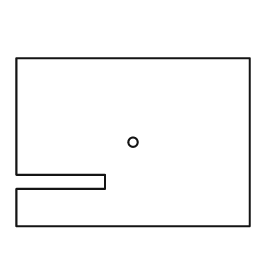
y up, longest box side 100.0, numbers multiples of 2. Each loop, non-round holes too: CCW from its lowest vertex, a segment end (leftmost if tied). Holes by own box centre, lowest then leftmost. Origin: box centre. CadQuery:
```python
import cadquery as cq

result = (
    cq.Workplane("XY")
    .moveTo(-50.0, -36.0)
    .lineTo(50.0, -36.0)
    .lineTo(50.0, 36.0)
    .lineTo(-50.0, 36.0)
    .lineTo(-50.0, -14.0)
    .lineTo(-12.0, -14.0)
    .lineTo(-12.0, -20.0)
    .lineTo(-50.0, -20.0)
    .close()
    .moveTo(0.0, 0.0)
    .circle(2.0)
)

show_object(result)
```